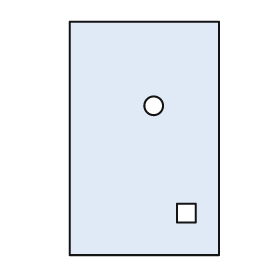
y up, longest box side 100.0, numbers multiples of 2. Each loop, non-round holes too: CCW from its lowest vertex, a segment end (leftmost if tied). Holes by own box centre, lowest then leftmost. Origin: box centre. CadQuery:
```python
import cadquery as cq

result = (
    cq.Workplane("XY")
    .moveTo(-32.0, -50.0)
    .lineTo(32.0, -50.0)
    .lineTo(32.0, 50.0)
    .lineTo(-32.0, 50.0)
    .close()
    .moveTo(14.0, -36.0)
    .lineTo(22.0, -36.0)
    .lineTo(22.0, -28.0)
    .lineTo(14.0, -28.0)
    .close()
    .moveTo(4.0, 14.0)
    .circle(4.0)
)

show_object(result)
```